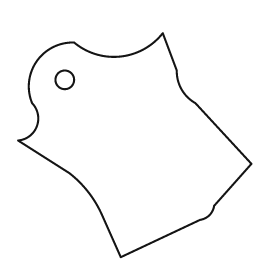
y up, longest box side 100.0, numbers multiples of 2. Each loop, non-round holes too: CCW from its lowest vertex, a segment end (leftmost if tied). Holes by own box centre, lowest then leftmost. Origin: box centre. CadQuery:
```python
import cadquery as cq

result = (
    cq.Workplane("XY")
    .moveTo(-6.0, -48.0)
    .lineTo(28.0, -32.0)
    .threePointArc((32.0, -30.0), (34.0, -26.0))
    .lineTo(50.0, -8.0)
    .lineTo(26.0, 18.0)
    .threePointArc((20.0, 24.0), (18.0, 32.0))
    .lineTo(12.0, 48.0)
    .threePointArc((-6.0, 38.0), (-26.0, 44.0))
    .threePointArc((-42.0, 36.0), (-44.0, 18.0))
    .threePointArc((-42.0, 8.0), (-50.0, 2.0))
    .lineTo(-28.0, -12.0)
    .threePointArc((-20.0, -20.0), (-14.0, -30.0))
    .close()
    .moveTo(-30.0, 28.0)
    .circle(4.0)
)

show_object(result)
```